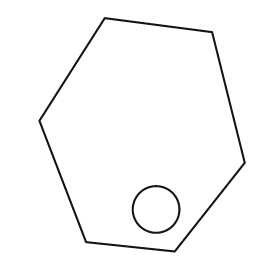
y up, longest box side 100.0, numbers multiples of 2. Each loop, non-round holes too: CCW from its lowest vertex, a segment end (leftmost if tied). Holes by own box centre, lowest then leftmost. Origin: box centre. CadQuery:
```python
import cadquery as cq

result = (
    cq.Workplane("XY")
    .moveTo(14.0, -50.0)
    .lineTo(44.0, -12.0)
    .lineTo(30.0, 44.0)
    .lineTo(-16.0, 50.0)
    .lineTo(-44.0, 6.0)
    .lineTo(-24.0, -46.0)
    .close()
    .moveTo(6.0, -32.0)
    .circle(10.0)
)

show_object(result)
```